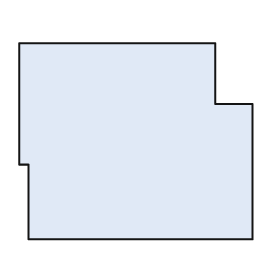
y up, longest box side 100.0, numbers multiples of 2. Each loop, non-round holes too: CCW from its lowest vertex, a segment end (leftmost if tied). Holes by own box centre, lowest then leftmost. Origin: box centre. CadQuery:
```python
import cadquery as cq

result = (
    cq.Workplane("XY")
    .moveTo(-46.0, -42.0)
    .lineTo(50.0, -42.0)
    .lineTo(50.0, 16.0)
    .lineTo(34.0, 16.0)
    .lineTo(34.0, 42.0)
    .lineTo(-50.0, 42.0)
    .lineTo(-50.0, -10.0)
    .lineTo(-46.0, -10.0)
    .close()
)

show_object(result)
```